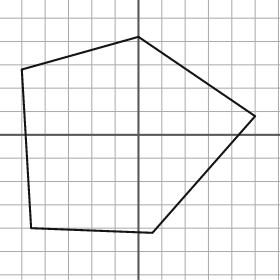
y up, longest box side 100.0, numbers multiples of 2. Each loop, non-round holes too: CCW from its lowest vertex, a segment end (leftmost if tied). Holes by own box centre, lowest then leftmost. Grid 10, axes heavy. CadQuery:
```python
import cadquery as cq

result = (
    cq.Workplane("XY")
    .moveTo(6.0, -42.0)
    .lineTo(50.0, 8.0)
    .lineTo(0.0, 42.0)
    .lineTo(-50.0, 28.0)
    .lineTo(-46.0, -40.0)
    .close()
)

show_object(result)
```